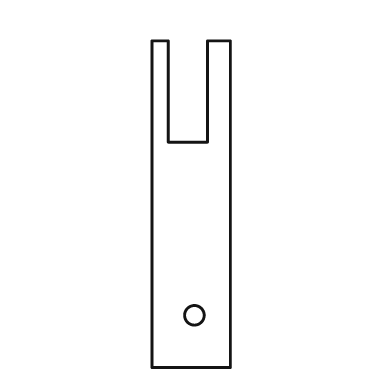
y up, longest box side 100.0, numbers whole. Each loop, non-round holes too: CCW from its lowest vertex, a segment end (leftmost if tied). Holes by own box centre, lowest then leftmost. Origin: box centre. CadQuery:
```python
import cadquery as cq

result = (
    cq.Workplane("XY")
    .moveTo(-12.0, -50.0)
    .lineTo(12.0, -50.0)
    .lineTo(12.0, 50.0)
    .lineTo(5.0, 50.0)
    .lineTo(5.0, 19.0)
    .lineTo(-7.0, 19.0)
    .lineTo(-7.0, 50.0)
    .lineTo(-12.0, 50.0)
    .close()
    .moveTo(1.0, -34.0)
    .circle(3.0)
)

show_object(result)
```